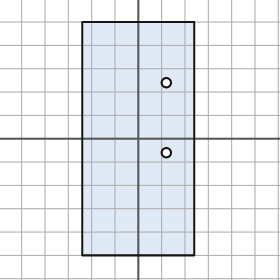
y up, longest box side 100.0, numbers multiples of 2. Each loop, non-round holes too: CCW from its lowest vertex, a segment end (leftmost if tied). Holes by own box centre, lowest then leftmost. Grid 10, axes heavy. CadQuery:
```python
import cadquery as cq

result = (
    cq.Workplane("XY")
    .moveTo(-24.0, -50.0)
    .lineTo(24.0, -50.0)
    .lineTo(24.0, 50.0)
    .lineTo(-24.0, 50.0)
    .close()
    .moveTo(12.0, -6.0)
    .circle(2.0)
    .moveTo(12.0, 24.0)
    .circle(2.0)
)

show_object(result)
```